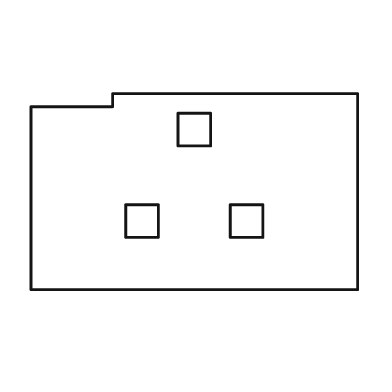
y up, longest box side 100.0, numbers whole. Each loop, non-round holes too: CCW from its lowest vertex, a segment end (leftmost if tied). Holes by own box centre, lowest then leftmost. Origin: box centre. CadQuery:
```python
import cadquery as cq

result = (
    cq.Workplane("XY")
    .moveTo(-50.0, -30.0)
    .lineTo(50.0, -30.0)
    .lineTo(50.0, 30.0)
    .lineTo(-25.0, 30.0)
    .lineTo(-25.0, 26.0)
    .lineTo(-50.0, 26.0)
    .close()
    .moveTo(-21.0, -14.0)
    .lineTo(-11.0, -14.0)
    .lineTo(-11.0, -4.0)
    .lineTo(-21.0, -4.0)
    .close()
    .moveTo(11.0, -14.0)
    .lineTo(21.0, -14.0)
    .lineTo(21.0, -4.0)
    .lineTo(11.0, -4.0)
    .close()
    .moveTo(-5.0, 14.0)
    .lineTo(5.0, 14.0)
    .lineTo(5.0, 24.0)
    .lineTo(-5.0, 24.0)
    .close()
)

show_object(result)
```